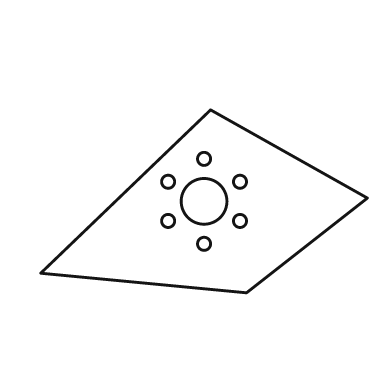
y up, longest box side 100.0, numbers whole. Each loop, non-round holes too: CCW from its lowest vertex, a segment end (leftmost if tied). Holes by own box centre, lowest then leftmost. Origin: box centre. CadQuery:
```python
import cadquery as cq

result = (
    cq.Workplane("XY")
    .moveTo(13.0, -28.0)
    .lineTo(50.0, 1.0)
    .lineTo(2.0, 28.0)
    .lineTo(-50.0, -22.0)
    .close()
    .moveTo(0.0, -13.0)
    .circle(2.0)
    .moveTo(-11.0, -6.0)
    .circle(2.0)
    .moveTo(11.0, -6.0)
    .circle(2.0)
    .moveTo(0.0, 0.0)
    .circle(7.0)
    .moveTo(-11.0, 6.0)
    .circle(2.0)
    .moveTo(11.0, 6.0)
    .circle(2.0)
    .moveTo(0.0, 13.0)
    .circle(2.0)
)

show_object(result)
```